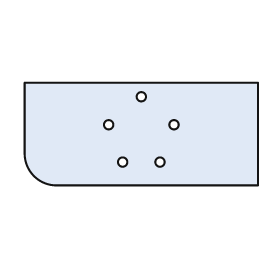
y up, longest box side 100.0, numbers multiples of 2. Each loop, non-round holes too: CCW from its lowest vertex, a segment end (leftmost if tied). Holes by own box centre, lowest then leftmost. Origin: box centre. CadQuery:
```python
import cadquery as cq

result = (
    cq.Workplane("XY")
    .moveTo(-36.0, -22.0)
    .lineTo(50.0, -22.0)
    .lineTo(50.0, 22.0)
    .lineTo(-50.0, 22.0)
    .lineTo(-50.0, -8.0)
    .threePointArc((-46.0, -18.0), (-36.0, -22.0))
    .close()
    .moveTo(-8.0, -12.0)
    .circle(2.0)
    .moveTo(8.0, -12.0)
    .circle(2.0)
    .moveTo(-14.0, 4.0)
    .circle(2.0)
    .moveTo(14.0, 4.0)
    .circle(2.0)
    .moveTo(0.0, 16.0)
    .circle(2.0)
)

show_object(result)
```